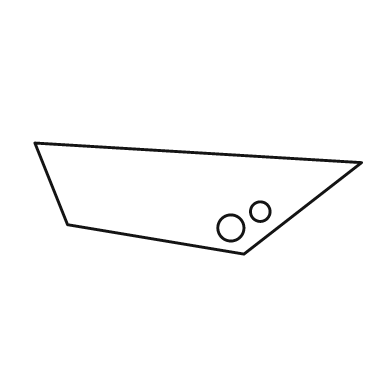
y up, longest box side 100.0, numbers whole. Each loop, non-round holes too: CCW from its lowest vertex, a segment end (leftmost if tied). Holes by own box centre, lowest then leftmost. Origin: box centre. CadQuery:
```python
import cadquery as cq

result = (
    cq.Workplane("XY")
    .moveTo(14.0, -17.0)
    .lineTo(50.0, 11.0)
    .lineTo(-50.0, 17.0)
    .lineTo(-40.0, -8.0)
    .close()
    .moveTo(10.0, -9.0)
    .circle(4.0)
    .moveTo(19.0, -4.0)
    .circle(3.0)
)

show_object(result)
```